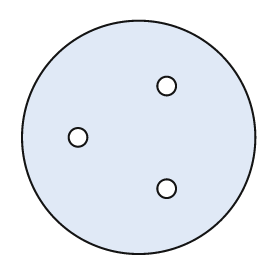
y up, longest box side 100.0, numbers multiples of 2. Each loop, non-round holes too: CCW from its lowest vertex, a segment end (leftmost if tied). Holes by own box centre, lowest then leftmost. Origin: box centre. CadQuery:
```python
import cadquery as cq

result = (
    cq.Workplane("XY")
    .moveTo(0.0, 0.0)
    .circle(50.0)
    .moveTo(12.0, -22.0)
    .circle(4.0)
    .moveTo(-26.0, 0.0)
    .circle(4.0)
    .moveTo(12.0, 22.0)
    .circle(4.0)
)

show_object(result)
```